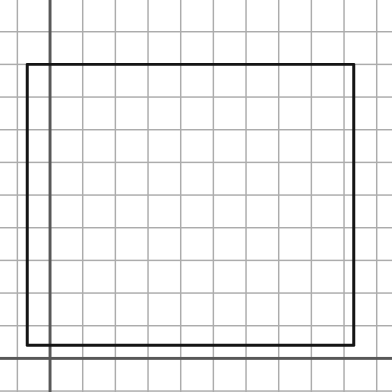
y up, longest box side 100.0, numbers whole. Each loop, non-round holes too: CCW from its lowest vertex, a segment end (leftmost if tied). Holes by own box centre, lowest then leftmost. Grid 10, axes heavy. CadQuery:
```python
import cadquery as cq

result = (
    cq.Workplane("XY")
    .moveTo(-7.0, 4.0)
    .lineTo(93.0, 4.0)
    .lineTo(93.0, 90.0)
    .lineTo(-7.0, 90.0)
    .close()
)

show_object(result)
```